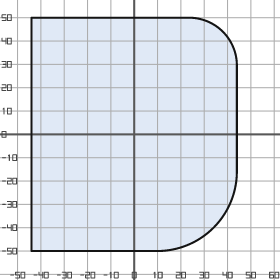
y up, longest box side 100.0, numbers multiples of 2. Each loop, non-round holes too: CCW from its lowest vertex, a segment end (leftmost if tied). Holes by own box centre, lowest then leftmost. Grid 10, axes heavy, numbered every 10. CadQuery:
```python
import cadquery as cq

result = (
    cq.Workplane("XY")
    .moveTo(-44.0, -50.0)
    .lineTo(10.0, -50.0)
    .threePointArc((34.0, -40.0), (44.0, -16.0))
    .lineTo(44.0, 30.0)
    .threePointArc((38.0, 44.0), (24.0, 50.0))
    .lineTo(-44.0, 50.0)
    .close()
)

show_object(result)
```